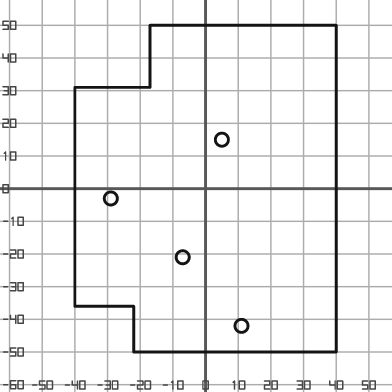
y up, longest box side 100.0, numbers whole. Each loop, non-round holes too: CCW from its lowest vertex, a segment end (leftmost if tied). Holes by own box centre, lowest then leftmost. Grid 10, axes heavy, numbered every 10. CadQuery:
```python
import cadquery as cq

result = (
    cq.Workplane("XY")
    .moveTo(-22.0, -50.0)
    .lineTo(40.0, -50.0)
    .lineTo(40.0, 50.0)
    .lineTo(-17.0, 50.0)
    .lineTo(-17.0, 31.0)
    .lineTo(-40.0, 31.0)
    .lineTo(-40.0, -36.0)
    .lineTo(-22.0, -36.0)
    .close()
    .moveTo(11.0, -42.0)
    .circle(2.0)
    .moveTo(-7.0, -21.0)
    .circle(2.0)
    .moveTo(-29.0, -3.0)
    .circle(2.0)
    .moveTo(5.0, 15.0)
    .circle(2.0)
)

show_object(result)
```